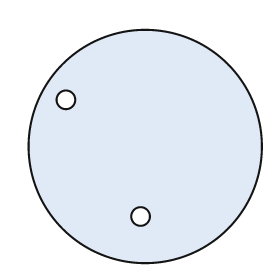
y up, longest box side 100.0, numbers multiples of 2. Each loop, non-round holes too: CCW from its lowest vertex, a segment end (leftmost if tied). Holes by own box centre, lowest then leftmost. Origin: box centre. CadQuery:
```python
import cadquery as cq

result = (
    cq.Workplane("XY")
    .moveTo(0.0, 0.0)
    .circle(50.0)
    .moveTo(-2.0, -30.0)
    .circle(4.0)
    .moveTo(-34.0, 20.0)
    .circle(4.0)
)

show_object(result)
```